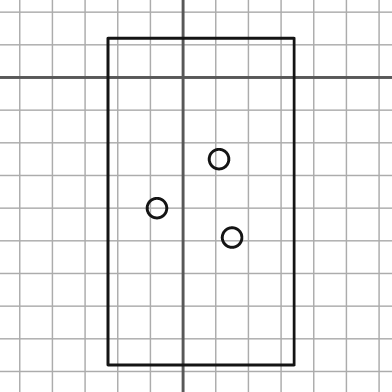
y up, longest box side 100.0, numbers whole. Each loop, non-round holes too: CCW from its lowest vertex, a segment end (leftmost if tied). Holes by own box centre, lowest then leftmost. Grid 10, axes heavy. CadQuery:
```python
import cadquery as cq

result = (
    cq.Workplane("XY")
    .moveTo(-23.0, -88.0)
    .lineTo(34.0, -88.0)
    .lineTo(34.0, 12.0)
    .lineTo(-23.0, 12.0)
    .close()
    .moveTo(15.0, -49.0)
    .circle(3.0)
    .moveTo(-8.0, -40.0)
    .circle(3.0)
    .moveTo(11.0, -25.0)
    .circle(3.0)
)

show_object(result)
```